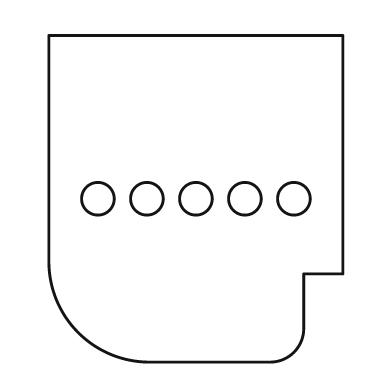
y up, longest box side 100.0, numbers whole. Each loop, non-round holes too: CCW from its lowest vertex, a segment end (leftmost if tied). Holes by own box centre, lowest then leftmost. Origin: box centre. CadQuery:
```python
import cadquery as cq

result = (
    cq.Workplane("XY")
    .moveTo(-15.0, -50.0)
    .lineTo(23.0, -50.0)
    .threePointArc((30.0, -47.0), (33.0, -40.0))
    .lineTo(33.0, -23.0)
    .lineTo(45.0, -23.0)
    .lineTo(45.0, 50.0)
    .lineTo(-45.0, 50.0)
    .lineTo(-45.0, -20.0)
    .threePointArc((-36.0, -41.0), (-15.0, -50.0))
    .close()
    .moveTo(-30.0, 0.0)
    .circle(5.0)
    .moveTo(-15.0, 0.0)
    .circle(5.0)
    .moveTo(0.0, 0.0)
    .circle(5.0)
    .moveTo(15.0, 0.0)
    .circle(5.0)
    .moveTo(30.0, 0.0)
    .circle(5.0)
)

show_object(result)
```